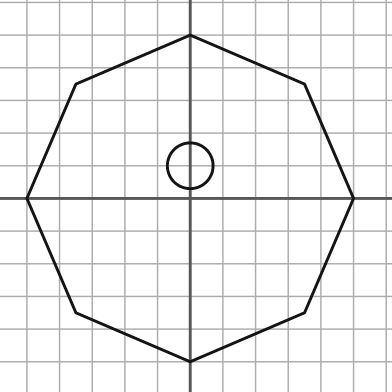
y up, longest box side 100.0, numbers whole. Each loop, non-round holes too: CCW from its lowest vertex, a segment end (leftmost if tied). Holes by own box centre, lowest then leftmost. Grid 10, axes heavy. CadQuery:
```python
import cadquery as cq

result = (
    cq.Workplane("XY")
    .moveTo(0.0, -50.0)
    .lineTo(35.0, -35.0)
    .lineTo(50.0, 0.0)
    .lineTo(35.0, 35.0)
    .lineTo(0.0, 50.0)
    .lineTo(-35.0, 35.0)
    .lineTo(-50.0, 0.0)
    .lineTo(-35.0, -35.0)
    .close()
    .moveTo(0.0, 10.0)
    .circle(7.0)
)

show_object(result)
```